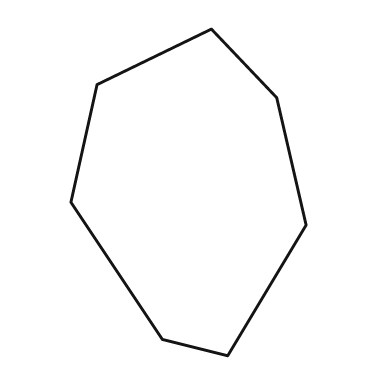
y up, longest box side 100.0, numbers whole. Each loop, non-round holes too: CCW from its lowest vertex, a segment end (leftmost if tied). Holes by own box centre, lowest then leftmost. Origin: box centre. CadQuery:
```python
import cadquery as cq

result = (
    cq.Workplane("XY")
    .moveTo(12.0, -50.0)
    .lineTo(36.0, -10.0)
    .lineTo(27.0, 29.0)
    .lineTo(7.0, 50.0)
    .lineTo(-28.0, 33.0)
    .lineTo(-36.0, -3.0)
    .lineTo(-8.0, -45.0)
    .close()
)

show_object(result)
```